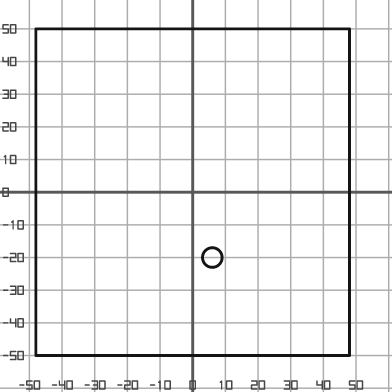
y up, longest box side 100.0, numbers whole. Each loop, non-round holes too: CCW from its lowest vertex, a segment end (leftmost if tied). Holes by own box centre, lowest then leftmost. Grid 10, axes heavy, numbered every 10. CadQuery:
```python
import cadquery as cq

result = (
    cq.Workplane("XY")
    .moveTo(-48.0, -50.0)
    .lineTo(48.0, -50.0)
    .lineTo(48.0, 50.0)
    .lineTo(-48.0, 50.0)
    .close()
    .moveTo(6.0, -20.0)
    .circle(3.0)
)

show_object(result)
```